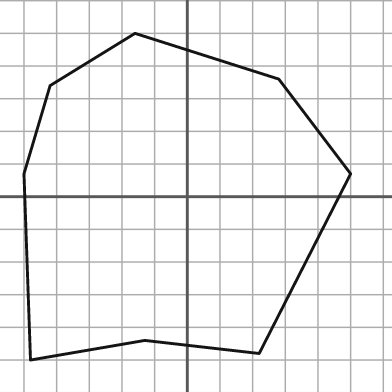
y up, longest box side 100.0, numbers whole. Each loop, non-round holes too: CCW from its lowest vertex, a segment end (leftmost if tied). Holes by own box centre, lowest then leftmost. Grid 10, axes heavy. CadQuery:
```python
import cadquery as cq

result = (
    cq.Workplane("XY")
    .moveTo(-48.0, -50.0)
    .lineTo(-13.0, -44.0)
    .lineTo(22.0, -48.0)
    .lineTo(50.0, 7.0)
    .lineTo(28.0, 36.0)
    .lineTo(-16.0, 50.0)
    .lineTo(-42.0, 34.0)
    .lineTo(-50.0, 7.0)
    .close()
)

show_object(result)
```